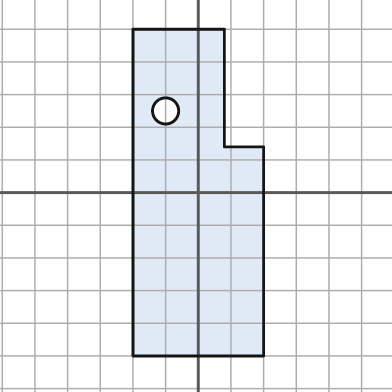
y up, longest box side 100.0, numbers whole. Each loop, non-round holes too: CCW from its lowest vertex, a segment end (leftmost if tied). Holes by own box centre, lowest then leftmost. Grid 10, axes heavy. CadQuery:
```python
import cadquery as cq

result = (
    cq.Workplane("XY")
    .moveTo(-20.0, -50.0)
    .lineTo(20.0, -50.0)
    .lineTo(20.0, 14.0)
    .lineTo(8.0, 14.0)
    .lineTo(8.0, 50.0)
    .lineTo(-20.0, 50.0)
    .close()
    .moveTo(-10.0, 25.0)
    .circle(4.0)
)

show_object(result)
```